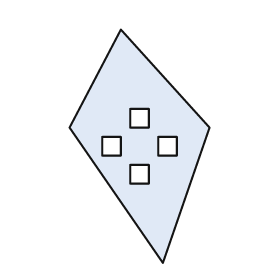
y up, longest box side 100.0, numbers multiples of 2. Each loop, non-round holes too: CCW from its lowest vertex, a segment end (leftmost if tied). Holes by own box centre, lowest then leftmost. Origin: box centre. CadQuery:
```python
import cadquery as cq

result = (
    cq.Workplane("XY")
    .moveTo(10.0, -50.0)
    .lineTo(30.0, 8.0)
    .lineTo(-8.0, 50.0)
    .lineTo(-30.0, 8.0)
    .close()
    .moveTo(-4.0, -16.0)
    .lineTo(4.0, -16.0)
    .lineTo(4.0, -8.0)
    .lineTo(-4.0, -8.0)
    .close()
    .moveTo(-16.0, -4.0)
    .lineTo(-8.0, -4.0)
    .lineTo(-8.0, 4.0)
    .lineTo(-16.0, 4.0)
    .close()
    .moveTo(8.0, -4.0)
    .lineTo(16.0, -4.0)
    .lineTo(16.0, 4.0)
    .lineTo(8.0, 4.0)
    .close()
    .moveTo(-4.0, 8.0)
    .lineTo(4.0, 8.0)
    .lineTo(4.0, 16.0)
    .lineTo(-4.0, 16.0)
    .close()
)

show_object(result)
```